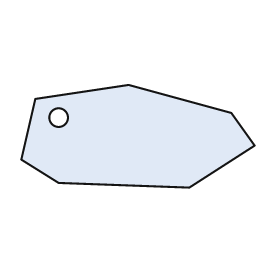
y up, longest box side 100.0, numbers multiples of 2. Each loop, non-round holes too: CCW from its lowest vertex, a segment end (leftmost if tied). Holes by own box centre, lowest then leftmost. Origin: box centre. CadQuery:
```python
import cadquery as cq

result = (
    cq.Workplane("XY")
    .moveTo(22.0, -22.0)
    .lineTo(50.0, -4.0)
    .lineTo(40.0, 10.0)
    .lineTo(-4.0, 22.0)
    .lineTo(-44.0, 16.0)
    .lineTo(-50.0, -10.0)
    .lineTo(-34.0, -20.0)
    .close()
    .moveTo(-34.0, 8.0)
    .circle(4.0)
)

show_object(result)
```